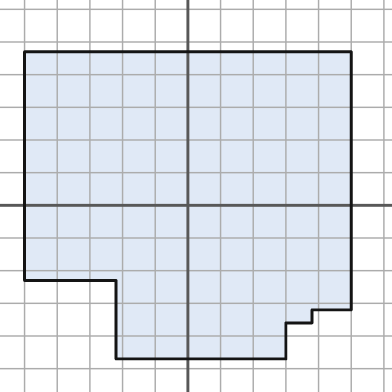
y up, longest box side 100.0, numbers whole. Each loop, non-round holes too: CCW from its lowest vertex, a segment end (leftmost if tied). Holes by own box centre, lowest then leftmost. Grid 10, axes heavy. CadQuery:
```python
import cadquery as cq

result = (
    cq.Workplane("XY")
    .moveTo(-22.0, -47.0)
    .lineTo(30.0, -47.0)
    .lineTo(30.0, -36.0)
    .lineTo(38.0, -36.0)
    .lineTo(38.0, -32.0)
    .lineTo(50.0, -32.0)
    .lineTo(50.0, 47.0)
    .lineTo(-50.0, 47.0)
    .lineTo(-50.0, -23.0)
    .lineTo(-22.0, -23.0)
    .close()
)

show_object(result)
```